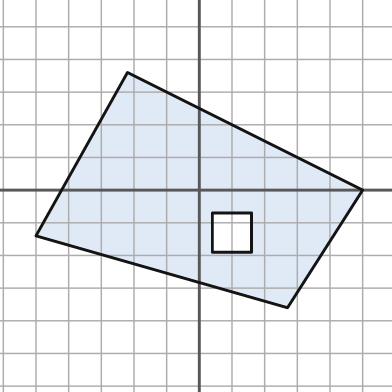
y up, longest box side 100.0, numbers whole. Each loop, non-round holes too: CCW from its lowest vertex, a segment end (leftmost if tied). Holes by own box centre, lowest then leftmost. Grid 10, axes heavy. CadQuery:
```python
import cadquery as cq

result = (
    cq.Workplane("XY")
    .moveTo(27.0, -36.0)
    .lineTo(50.0, 0.0)
    .lineTo(-22.0, 36.0)
    .lineTo(-50.0, -14.0)
    .close()
    .moveTo(4.0, -19.0)
    .lineTo(16.0, -19.0)
    .lineTo(16.0, -7.0)
    .lineTo(4.0, -7.0)
    .close()
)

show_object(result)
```